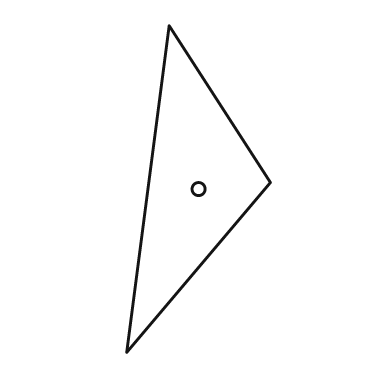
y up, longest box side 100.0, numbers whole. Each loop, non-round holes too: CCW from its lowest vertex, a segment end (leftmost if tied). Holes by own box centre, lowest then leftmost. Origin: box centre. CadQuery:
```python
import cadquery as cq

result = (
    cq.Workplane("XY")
    .moveTo(-22.0, -50.0)
    .lineTo(22.0, 2.0)
    .lineTo(-9.0, 50.0)
    .close()
    .moveTo(0.0, 0.0)
    .circle(2.0)
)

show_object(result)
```